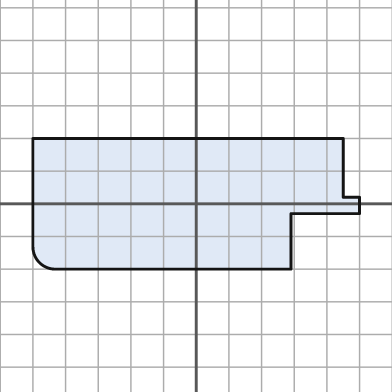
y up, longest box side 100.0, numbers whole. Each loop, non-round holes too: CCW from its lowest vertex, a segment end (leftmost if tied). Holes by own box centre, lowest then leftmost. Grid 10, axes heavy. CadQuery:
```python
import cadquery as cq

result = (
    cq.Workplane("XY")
    .moveTo(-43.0, -20.0)
    .lineTo(29.0, -20.0)
    .lineTo(29.0, -3.0)
    .lineTo(50.0, -3.0)
    .lineTo(50.0, 2.0)
    .lineTo(45.0, 2.0)
    .lineTo(45.0, 20.0)
    .lineTo(-50.0, 20.0)
    .lineTo(-50.0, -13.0)
    .threePointArc((-48.0, -18.0), (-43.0, -20.0))
    .close()
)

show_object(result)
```